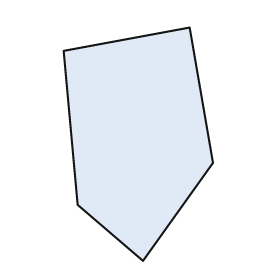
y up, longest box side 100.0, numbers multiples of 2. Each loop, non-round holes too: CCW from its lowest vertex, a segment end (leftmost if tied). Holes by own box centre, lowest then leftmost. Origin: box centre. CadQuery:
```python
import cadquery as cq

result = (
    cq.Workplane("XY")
    .moveTo(2.0, -50.0)
    .lineTo(32.0, -8.0)
    .lineTo(22.0, 50.0)
    .lineTo(-32.0, 40.0)
    .lineTo(-26.0, -26.0)
    .close()
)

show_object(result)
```